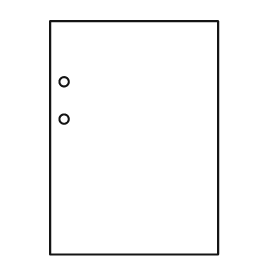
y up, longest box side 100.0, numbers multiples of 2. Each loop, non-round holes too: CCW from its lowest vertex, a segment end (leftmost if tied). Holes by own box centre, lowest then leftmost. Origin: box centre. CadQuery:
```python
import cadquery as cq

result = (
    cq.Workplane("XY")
    .moveTo(-36.0, -50.0)
    .lineTo(36.0, -50.0)
    .lineTo(36.0, 50.0)
    .lineTo(-36.0, 50.0)
    .close()
    .moveTo(-30.0, 8.0)
    .circle(2.0)
    .moveTo(-30.0, 24.0)
    .circle(2.0)
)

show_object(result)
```